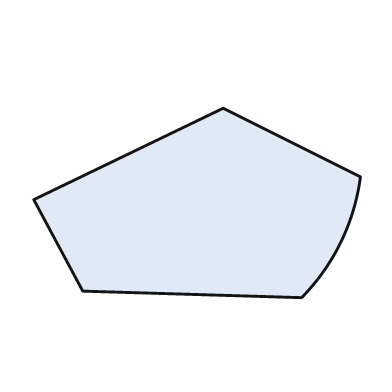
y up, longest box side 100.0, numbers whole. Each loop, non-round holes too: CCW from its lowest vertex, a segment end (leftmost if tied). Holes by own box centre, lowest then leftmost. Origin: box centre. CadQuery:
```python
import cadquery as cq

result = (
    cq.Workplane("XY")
    .moveTo(32.0, -29.0)
    .threePointArc((44.0, -12.0), (50.0, 8.0))
    .lineTo(8.0, 29.0)
    .lineTo(-50.0, 1.0)
    .lineTo(-35.0, -27.0)
    .close()
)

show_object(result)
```